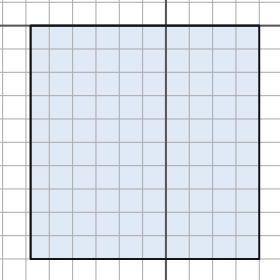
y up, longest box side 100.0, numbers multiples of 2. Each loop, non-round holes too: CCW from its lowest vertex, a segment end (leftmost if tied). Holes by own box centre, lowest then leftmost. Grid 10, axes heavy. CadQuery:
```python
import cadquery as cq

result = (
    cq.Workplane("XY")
    .moveTo(-58.0, -100.0)
    .lineTo(40.0, -100.0)
    .lineTo(40.0, 0.0)
    .lineTo(-58.0, 0.0)
    .close()
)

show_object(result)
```